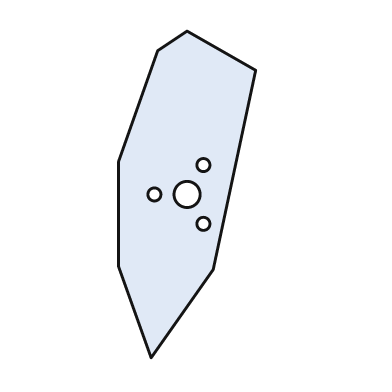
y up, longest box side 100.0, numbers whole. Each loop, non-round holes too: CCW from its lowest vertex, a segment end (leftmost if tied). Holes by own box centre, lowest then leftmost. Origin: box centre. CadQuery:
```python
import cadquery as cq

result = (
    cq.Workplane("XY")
    .moveTo(-11.0, -50.0)
    .lineTo(8.0, -23.0)
    .lineTo(21.0, 38.0)
    .lineTo(0.0, 50.0)
    .lineTo(-9.0, 44.0)
    .lineTo(-21.0, 10.0)
    .lineTo(-21.0, -22.0)
    .close()
    .moveTo(5.0, -9.0)
    .circle(2.0)
    .moveTo(-10.0, 0.0)
    .circle(2.0)
    .moveTo(0.0, 0.0)
    .circle(4.0)
    .moveTo(5.0, 9.0)
    .circle(2.0)
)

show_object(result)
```